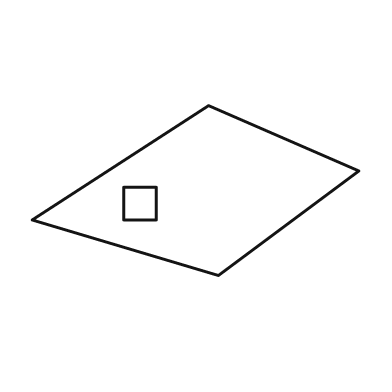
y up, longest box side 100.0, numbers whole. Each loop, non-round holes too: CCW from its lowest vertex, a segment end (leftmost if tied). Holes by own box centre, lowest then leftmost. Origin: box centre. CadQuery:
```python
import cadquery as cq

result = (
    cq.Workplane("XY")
    .moveTo(7.0, -26.0)
    .lineTo(50.0, 6.0)
    .lineTo(4.0, 26.0)
    .lineTo(-50.0, -9.0)
    .close()
    .moveTo(-22.0, -9.0)
    .lineTo(-12.0, -9.0)
    .lineTo(-12.0, 1.0)
    .lineTo(-22.0, 1.0)
    .close()
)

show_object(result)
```